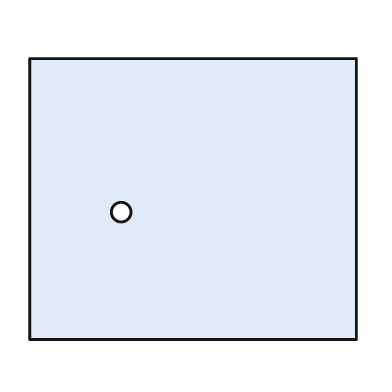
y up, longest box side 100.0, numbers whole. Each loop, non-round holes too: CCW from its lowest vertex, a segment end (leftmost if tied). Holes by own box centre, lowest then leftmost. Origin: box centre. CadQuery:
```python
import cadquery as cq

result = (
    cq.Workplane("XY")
    .moveTo(-50.0, -43.0)
    .lineTo(50.0, -43.0)
    .lineTo(50.0, 43.0)
    .lineTo(-50.0, 43.0)
    .close()
    .moveTo(-22.0, -4.0)
    .circle(3.0)
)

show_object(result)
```